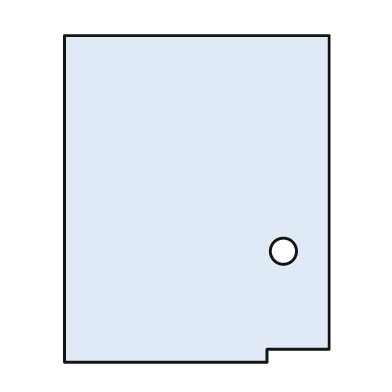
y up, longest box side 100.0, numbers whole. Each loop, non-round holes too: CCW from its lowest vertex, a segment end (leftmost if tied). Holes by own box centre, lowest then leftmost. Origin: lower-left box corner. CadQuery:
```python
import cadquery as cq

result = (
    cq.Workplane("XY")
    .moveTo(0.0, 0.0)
    .lineTo(62.0, 0.0)
    .lineTo(62.0, 4.0)
    .lineTo(81.0, 4.0)
    .lineTo(81.0, 100.0)
    .lineTo(0.0, 100.0)
    .close()
    .moveTo(67.0, 34.0)
    .circle(4.0)
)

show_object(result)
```